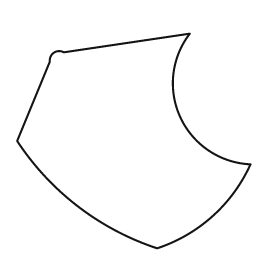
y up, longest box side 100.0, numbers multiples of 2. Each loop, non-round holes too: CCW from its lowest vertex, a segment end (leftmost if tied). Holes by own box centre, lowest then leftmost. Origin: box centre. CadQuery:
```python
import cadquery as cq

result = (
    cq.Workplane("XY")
    .moveTo(10.0, -46.0)
    .threePointArc((34.0, -32.0), (50.0, -10.0))
    .threePointArc((20.0, 10.0), (24.0, 46.0))
    .lineTo(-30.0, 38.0)
    .threePointArc((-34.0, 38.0), (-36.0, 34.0))
    .lineTo(-50.0, 0.0)
    .threePointArc((-24.0, -28.0), (10.0, -46.0))
    .close()
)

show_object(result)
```